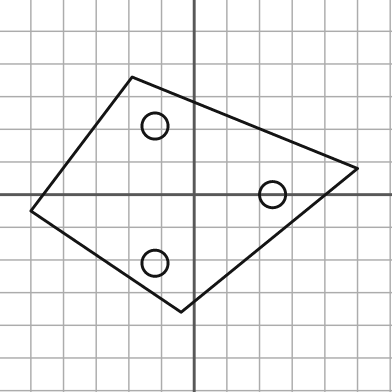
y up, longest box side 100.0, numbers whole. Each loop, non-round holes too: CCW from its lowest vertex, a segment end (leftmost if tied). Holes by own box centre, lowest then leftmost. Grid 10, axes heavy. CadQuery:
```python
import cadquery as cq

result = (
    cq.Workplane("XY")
    .moveTo(-4.0, -36.0)
    .lineTo(50.0, 8.0)
    .lineTo(-19.0, 36.0)
    .lineTo(-50.0, -5.0)
    .close()
    .moveTo(-12.0, -21.0)
    .circle(4.0)
    .moveTo(24.0, 0.0)
    .circle(4.0)
    .moveTo(-12.0, 21.0)
    .circle(4.0)
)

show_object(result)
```